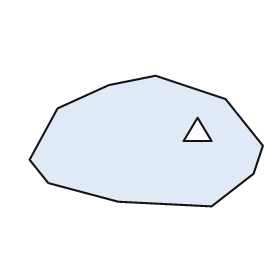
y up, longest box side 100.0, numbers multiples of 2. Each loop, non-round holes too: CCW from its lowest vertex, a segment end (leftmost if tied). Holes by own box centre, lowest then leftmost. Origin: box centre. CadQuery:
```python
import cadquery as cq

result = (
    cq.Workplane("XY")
    .moveTo(28.0, -28.0)
    .lineTo(46.0, -14.0)
    .lineTo(50.0, -2.0)
    .lineTo(34.0, 18.0)
    .lineTo(4.0, 28.0)
    .lineTo(-16.0, 24.0)
    .lineTo(-38.0, 14.0)
    .lineTo(-50.0, -8.0)
    .lineTo(-42.0, -18.0)
    .lineTo(-12.0, -26.0)
    .close()
    .moveTo(16.0, 0.0)
    .lineTo(28.0, 0.0)
    .lineTo(22.0, 10.0)
    .close()
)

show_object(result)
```